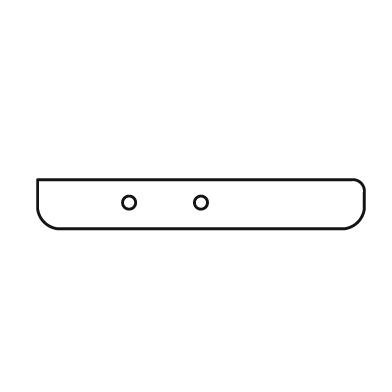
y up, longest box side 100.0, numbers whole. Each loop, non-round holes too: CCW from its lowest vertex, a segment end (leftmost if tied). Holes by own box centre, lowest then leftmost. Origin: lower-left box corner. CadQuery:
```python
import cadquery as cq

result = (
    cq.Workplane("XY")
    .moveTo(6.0, 0.0)
    .lineTo(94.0, 0.0)
    .threePointArc((98.0, 2.0), (100.0, 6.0))
    .lineTo(100.0, 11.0)
    .threePointArc((99.0, 14.0), (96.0, 15.0))
    .lineTo(0.0, 15.0)
    .lineTo(0.0, 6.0)
    .threePointArc((2.0, 2.0), (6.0, 0.0))
    .close()
    .moveTo(28.0, 8.0)
    .circle(2.0)
    .moveTo(50.0, 8.0)
    .circle(2.0)
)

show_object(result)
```